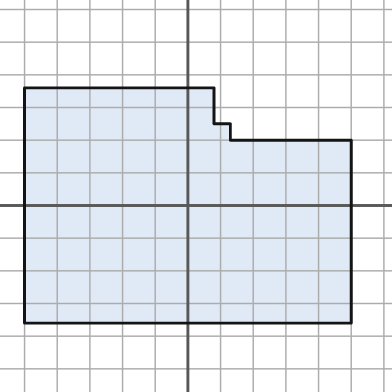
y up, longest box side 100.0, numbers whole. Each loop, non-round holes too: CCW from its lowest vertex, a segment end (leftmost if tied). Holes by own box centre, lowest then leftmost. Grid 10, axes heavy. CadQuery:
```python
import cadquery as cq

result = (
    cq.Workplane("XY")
    .moveTo(-50.0, -36.0)
    .lineTo(50.0, -36.0)
    .lineTo(50.0, 20.0)
    .lineTo(13.0, 20.0)
    .lineTo(13.0, 25.0)
    .lineTo(8.0, 25.0)
    .lineTo(8.0, 36.0)
    .lineTo(-50.0, 36.0)
    .close()
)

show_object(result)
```